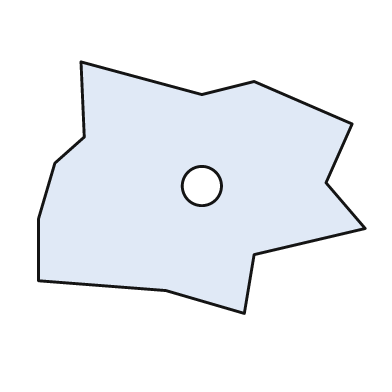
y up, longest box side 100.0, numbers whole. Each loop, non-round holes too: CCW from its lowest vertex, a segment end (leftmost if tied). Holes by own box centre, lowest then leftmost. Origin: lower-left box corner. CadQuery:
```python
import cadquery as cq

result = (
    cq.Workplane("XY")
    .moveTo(63.0, 0.0)
    .lineTo(66.0, 18.0)
    .lineTo(100.0, 26.0)
    .lineTo(88.0, 40.0)
    .lineTo(96.0, 58.0)
    .lineTo(66.0, 71.0)
    .lineTo(50.0, 67.0)
    .lineTo(13.0, 77.0)
    .lineTo(14.0, 54.0)
    .lineTo(5.0, 46.0)
    .lineTo(0.0, 29.0)
    .lineTo(0.0, 10.0)
    .lineTo(39.0, 7.0)
    .close()
    .moveTo(50.0, 39.0)
    .circle(6.0)
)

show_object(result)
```